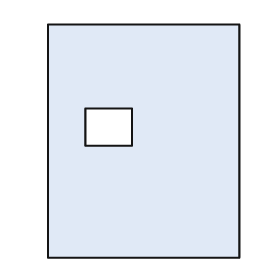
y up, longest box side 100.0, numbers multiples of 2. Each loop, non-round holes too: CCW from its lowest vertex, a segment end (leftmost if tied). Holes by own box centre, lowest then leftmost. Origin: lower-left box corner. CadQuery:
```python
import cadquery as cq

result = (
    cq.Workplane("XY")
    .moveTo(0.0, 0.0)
    .lineTo(82.0, 0.0)
    .lineTo(82.0, 100.0)
    .lineTo(0.0, 100.0)
    .close()
    .moveTo(16.0, 48.0)
    .lineTo(36.0, 48.0)
    .lineTo(36.0, 64.0)
    .lineTo(16.0, 64.0)
    .close()
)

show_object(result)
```